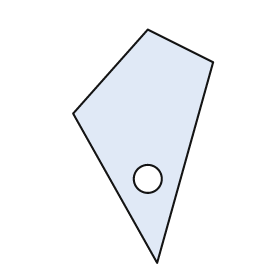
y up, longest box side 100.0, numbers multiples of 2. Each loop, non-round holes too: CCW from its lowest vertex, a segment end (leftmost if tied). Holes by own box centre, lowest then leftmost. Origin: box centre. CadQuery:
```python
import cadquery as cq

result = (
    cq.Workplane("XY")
    .moveTo(6.0, -50.0)
    .lineTo(30.0, 36.0)
    .lineTo(2.0, 50.0)
    .lineTo(-30.0, 14.0)
    .close()
    .moveTo(2.0, -14.0)
    .circle(6.0)
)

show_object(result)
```